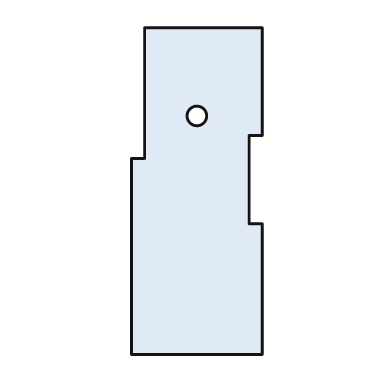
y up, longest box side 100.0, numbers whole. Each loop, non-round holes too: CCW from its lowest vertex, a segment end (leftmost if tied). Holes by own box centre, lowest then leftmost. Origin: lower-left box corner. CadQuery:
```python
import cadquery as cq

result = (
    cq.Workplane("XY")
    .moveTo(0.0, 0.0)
    .lineTo(40.0, 0.0)
    .lineTo(40.0, 40.0)
    .lineTo(36.0, 40.0)
    .lineTo(36.0, 67.0)
    .lineTo(40.0, 67.0)
    .lineTo(40.0, 100.0)
    .lineTo(4.0, 100.0)
    .lineTo(4.0, 60.0)
    .lineTo(0.0, 60.0)
    .close()
    .moveTo(20.0, 73.0)
    .circle(3.0)
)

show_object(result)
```